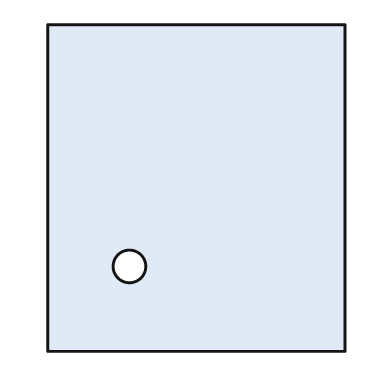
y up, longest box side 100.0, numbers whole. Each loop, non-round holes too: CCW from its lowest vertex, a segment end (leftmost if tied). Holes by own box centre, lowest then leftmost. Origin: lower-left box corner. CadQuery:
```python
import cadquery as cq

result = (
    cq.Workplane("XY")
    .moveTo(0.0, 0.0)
    .lineTo(91.0, 0.0)
    .lineTo(91.0, 100.0)
    .lineTo(0.0, 100.0)
    .close()
    .moveTo(25.0, 26.0)
    .circle(5.0)
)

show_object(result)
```